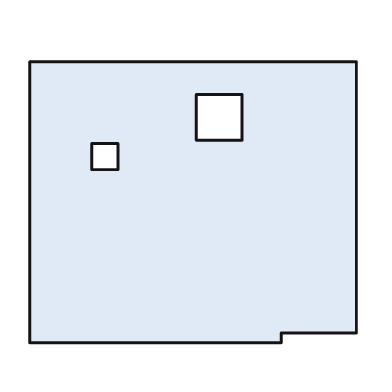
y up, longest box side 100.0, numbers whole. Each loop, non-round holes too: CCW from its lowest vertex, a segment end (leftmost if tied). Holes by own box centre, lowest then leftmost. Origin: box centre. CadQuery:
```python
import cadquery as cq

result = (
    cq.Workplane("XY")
    .moveTo(-50.0, -43.0)
    .lineTo(27.0, -43.0)
    .lineTo(27.0, -40.0)
    .lineTo(50.0, -40.0)
    .lineTo(50.0, 43.0)
    .lineTo(-50.0, 43.0)
    .close()
    .moveTo(-31.0, 10.0)
    .lineTo(-23.0, 10.0)
    .lineTo(-23.0, 18.0)
    .lineTo(-31.0, 18.0)
    .close()
    .moveTo(1.0, 19.0)
    .lineTo(15.0, 19.0)
    .lineTo(15.0, 33.0)
    .lineTo(1.0, 33.0)
    .close()
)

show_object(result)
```